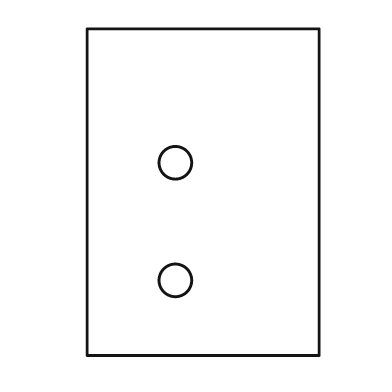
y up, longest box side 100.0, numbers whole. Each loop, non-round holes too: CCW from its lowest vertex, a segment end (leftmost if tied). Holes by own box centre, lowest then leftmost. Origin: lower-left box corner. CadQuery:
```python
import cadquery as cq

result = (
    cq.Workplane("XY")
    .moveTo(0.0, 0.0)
    .lineTo(71.0, 0.0)
    .lineTo(71.0, 100.0)
    .lineTo(0.0, 100.0)
    .close()
    .moveTo(27.0, 23.0)
    .circle(5.0)
    .moveTo(27.0, 59.0)
    .circle(5.0)
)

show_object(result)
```